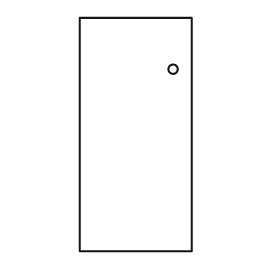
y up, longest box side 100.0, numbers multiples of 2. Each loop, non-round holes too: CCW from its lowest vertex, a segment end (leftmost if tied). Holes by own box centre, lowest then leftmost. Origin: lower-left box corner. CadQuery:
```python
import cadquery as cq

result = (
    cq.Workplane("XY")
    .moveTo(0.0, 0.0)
    .lineTo(48.0, 0.0)
    .lineTo(48.0, 100.0)
    .lineTo(0.0, 100.0)
    .close()
    .moveTo(40.0, 78.0)
    .circle(2.0)
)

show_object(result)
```